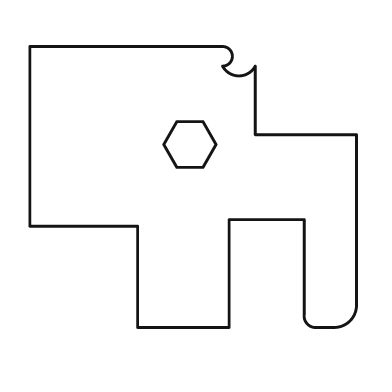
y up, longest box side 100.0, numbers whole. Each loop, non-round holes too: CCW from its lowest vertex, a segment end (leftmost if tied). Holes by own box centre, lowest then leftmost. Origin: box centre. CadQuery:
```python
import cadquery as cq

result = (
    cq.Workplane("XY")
    .moveTo(-17.0, -43.0)
    .lineTo(11.0, -43.0)
    .lineTo(11.0, -10.0)
    .lineTo(34.0, -10.0)
    .lineTo(34.0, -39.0)
    .threePointArc((35.0, -42.0), (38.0, -43.0))
    .lineTo(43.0, -43.0)
    .threePointArc((48.0, -41.0), (50.0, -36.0))
    .lineTo(50.0, 16.0)
    .lineTo(19.0, 16.0)
    .lineTo(19.0, 37.0)
    .threePointArc((14.0, 34.0), (9.0, 37.0))
    .threePointArc((12.0, 40.0), (9.0, 43.0))
    .lineTo(-50.0, 43.0)
    .lineTo(-50.0, -12.0)
    .lineTo(-17.0, -12.0)
    .close()
    .moveTo(-5.0, 6.0)
    .lineTo(3.0, 6.0)
    .lineTo(7.0, 13.0)
    .lineTo(3.0, 20.0)
    .lineTo(-5.0, 20.0)
    .lineTo(-9.0, 13.0)
    .close()
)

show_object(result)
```